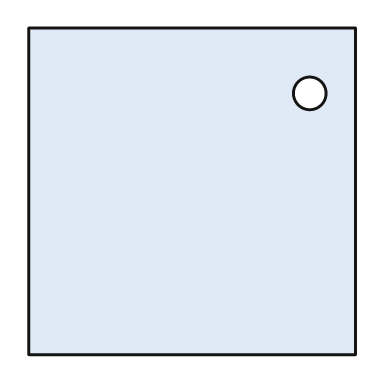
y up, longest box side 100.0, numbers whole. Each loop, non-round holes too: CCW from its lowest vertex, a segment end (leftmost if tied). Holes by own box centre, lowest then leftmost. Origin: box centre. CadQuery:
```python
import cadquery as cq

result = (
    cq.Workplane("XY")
    .moveTo(-50.0, -50.0)
    .lineTo(50.0, -50.0)
    .lineTo(50.0, 50.0)
    .lineTo(-50.0, 50.0)
    .close()
    .moveTo(36.0, 30.0)
    .circle(5.0)
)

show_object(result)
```